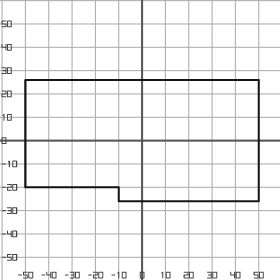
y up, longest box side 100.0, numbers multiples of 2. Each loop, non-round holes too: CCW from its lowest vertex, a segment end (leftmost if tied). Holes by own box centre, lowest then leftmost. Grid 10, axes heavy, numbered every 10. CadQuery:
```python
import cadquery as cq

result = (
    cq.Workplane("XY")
    .moveTo(-10.0, -26.0)
    .lineTo(50.0, -26.0)
    .lineTo(50.0, 26.0)
    .lineTo(-50.0, 26.0)
    .lineTo(-50.0, -20.0)
    .lineTo(-10.0, -20.0)
    .close()
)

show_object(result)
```